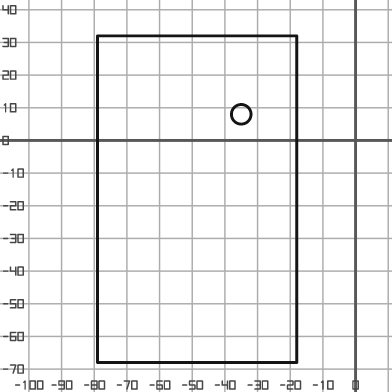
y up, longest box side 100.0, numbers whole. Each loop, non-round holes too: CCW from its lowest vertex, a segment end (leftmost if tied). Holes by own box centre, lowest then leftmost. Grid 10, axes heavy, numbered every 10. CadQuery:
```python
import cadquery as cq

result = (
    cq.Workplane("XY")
    .moveTo(-79.0, -68.0)
    .lineTo(-18.0, -68.0)
    .lineTo(-18.0, 32.0)
    .lineTo(-79.0, 32.0)
    .close()
    .moveTo(-35.0, 8.0)
    .circle(3.0)
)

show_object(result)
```